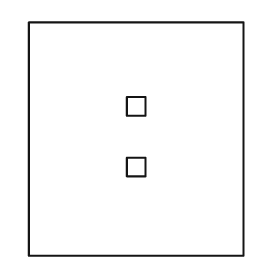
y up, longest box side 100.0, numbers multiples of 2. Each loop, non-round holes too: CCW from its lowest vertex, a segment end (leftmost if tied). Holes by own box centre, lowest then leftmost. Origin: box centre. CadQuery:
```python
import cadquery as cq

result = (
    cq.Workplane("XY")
    .moveTo(-46.0, -50.0)
    .lineTo(46.0, -50.0)
    .lineTo(46.0, 50.0)
    .lineTo(-46.0, 50.0)
    .close()
    .moveTo(-4.0, -16.0)
    .lineTo(4.0, -16.0)
    .lineTo(4.0, -8.0)
    .lineTo(-4.0, -8.0)
    .close()
    .moveTo(-4.0, 10.0)
    .lineTo(4.0, 10.0)
    .lineTo(4.0, 18.0)
    .lineTo(-4.0, 18.0)
    .close()
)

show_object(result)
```